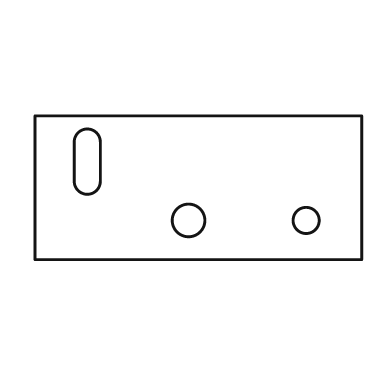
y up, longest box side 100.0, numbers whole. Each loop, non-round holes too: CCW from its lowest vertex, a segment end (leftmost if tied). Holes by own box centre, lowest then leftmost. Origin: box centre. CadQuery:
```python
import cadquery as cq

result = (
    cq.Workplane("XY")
    .moveTo(-50.0, -22.0)
    .lineTo(50.0, -22.0)
    .lineTo(50.0, 22.0)
    .lineTo(-50.0, 22.0)
    .close()
    .moveTo(-3.0, -10.0)
    .circle(5.0)
    .moveTo(33.0, -10.0)
    .circle(4.0)
    .moveTo(-38.0, 2.0)
    .threePointArc((-34.0, -2.0), (-30.0, 2.0))
    .lineTo(-30.0, 14.0)
    .threePointArc((-34.0, 18.0), (-38.0, 14.0))
    .close()
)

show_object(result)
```